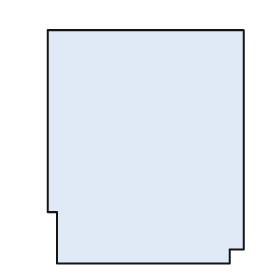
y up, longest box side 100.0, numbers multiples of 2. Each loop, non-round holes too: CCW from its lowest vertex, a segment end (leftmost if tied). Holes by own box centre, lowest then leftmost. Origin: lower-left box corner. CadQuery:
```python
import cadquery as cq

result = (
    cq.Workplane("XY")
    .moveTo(4.0, 0.0)
    .lineTo(78.0, 0.0)
    .lineTo(78.0, 6.0)
    .lineTo(84.0, 6.0)
    .lineTo(84.0, 100.0)
    .lineTo(0.0, 100.0)
    .lineTo(0.0, 22.0)
    .lineTo(4.0, 22.0)
    .close()
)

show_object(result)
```